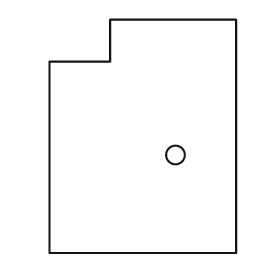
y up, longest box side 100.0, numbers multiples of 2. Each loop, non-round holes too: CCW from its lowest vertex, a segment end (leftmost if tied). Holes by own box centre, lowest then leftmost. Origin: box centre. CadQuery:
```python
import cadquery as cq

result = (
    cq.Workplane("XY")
    .moveTo(-40.0, -50.0)
    .lineTo(40.0, -50.0)
    .lineTo(40.0, 50.0)
    .lineTo(-14.0, 50.0)
    .lineTo(-14.0, 32.0)
    .lineTo(-40.0, 32.0)
    .close()
    .moveTo(14.0, -8.0)
    .circle(4.0)
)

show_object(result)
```